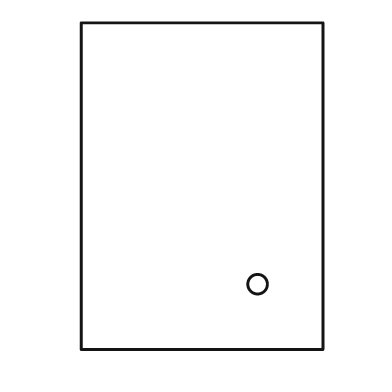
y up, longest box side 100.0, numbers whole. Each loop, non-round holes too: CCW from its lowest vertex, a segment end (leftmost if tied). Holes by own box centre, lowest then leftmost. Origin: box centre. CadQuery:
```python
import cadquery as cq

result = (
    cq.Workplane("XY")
    .moveTo(-37.0, -50.0)
    .lineTo(37.0, -50.0)
    .lineTo(37.0, 50.0)
    .lineTo(-37.0, 50.0)
    .close()
    .moveTo(17.0, -30.0)
    .circle(3.0)
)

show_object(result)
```